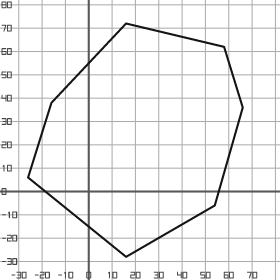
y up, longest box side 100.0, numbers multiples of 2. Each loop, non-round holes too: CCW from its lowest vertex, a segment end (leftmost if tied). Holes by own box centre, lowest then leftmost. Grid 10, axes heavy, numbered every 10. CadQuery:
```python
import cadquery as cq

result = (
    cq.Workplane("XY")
    .moveTo(16.0, -28.0)
    .lineTo(54.0, -6.0)
    .lineTo(66.0, 36.0)
    .lineTo(58.0, 62.0)
    .lineTo(16.0, 72.0)
    .lineTo(-16.0, 38.0)
    .lineTo(-26.0, 6.0)
    .close()
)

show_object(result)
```